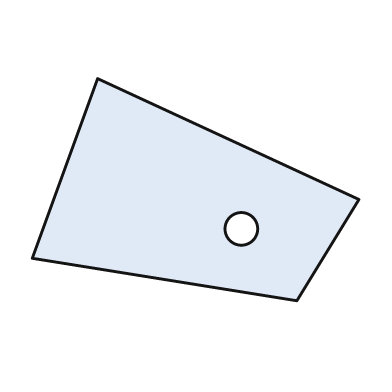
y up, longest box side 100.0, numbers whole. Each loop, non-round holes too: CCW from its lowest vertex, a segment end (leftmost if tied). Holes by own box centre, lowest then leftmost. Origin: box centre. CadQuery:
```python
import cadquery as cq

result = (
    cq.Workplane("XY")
    .moveTo(31.0, -34.0)
    .lineTo(50.0, -3.0)
    .lineTo(-30.0, 34.0)
    .lineTo(-50.0, -21.0)
    .close()
    .moveTo(14.0, -12.0)
    .circle(5.0)
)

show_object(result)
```